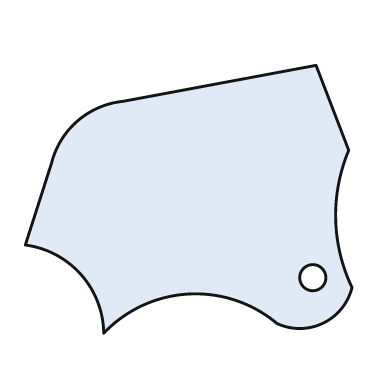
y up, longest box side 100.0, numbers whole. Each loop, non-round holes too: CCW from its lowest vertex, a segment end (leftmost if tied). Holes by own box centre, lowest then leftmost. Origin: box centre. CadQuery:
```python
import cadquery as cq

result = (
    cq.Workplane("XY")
    .moveTo(-26.0, -41.0)
    .threePointArc((0.0, -29.0), (27.0, -38.0))
    .threePointArc((41.0, -38.0), (50.0, -27.0))
    .threePointArc((45.0, -6.0), (49.0, 15.0))
    .lineTo(39.0, 41.0)
    .lineTo(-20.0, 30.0)
    .threePointArc((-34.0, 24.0), (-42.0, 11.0))
    .lineTo(-50.0, -14.0)
    .threePointArc((-33.0, -23.0), (-26.0, -41.0))
    .close()
    .moveTo(38.0, -24.0)
    .circle(4.0)
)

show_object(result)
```